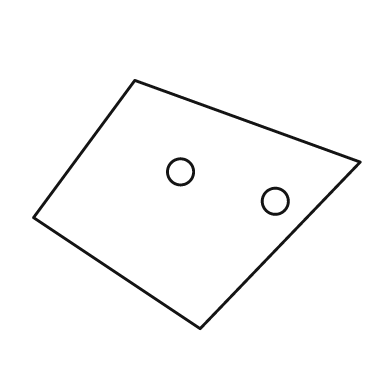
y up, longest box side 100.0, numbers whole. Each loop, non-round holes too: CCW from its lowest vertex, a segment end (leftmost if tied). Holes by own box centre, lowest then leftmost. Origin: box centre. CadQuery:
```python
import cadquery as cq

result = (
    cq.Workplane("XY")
    .moveTo(1.0, -38.0)
    .lineTo(50.0, 13.0)
    .lineTo(-19.0, 38.0)
    .lineTo(-50.0, -4.0)
    .close()
    .moveTo(24.0, 1.0)
    .circle(4.0)
    .moveTo(-5.0, 10.0)
    .circle(4.0)
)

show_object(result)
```